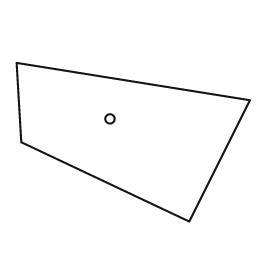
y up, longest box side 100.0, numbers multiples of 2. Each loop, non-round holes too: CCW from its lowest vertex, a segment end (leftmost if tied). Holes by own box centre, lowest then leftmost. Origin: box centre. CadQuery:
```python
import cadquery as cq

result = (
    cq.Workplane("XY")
    .moveTo(24.0, -34.0)
    .lineTo(50.0, 18.0)
    .lineTo(-50.0, 34.0)
    .lineTo(-48.0, 0.0)
    .close()
    .moveTo(-10.0, 10.0)
    .circle(2.0)
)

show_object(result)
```